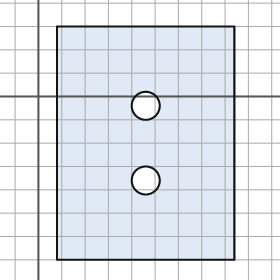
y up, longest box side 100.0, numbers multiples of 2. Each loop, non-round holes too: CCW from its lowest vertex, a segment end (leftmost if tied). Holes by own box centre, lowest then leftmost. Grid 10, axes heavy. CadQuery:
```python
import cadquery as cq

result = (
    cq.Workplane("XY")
    .moveTo(8.0, -70.0)
    .lineTo(84.0, -70.0)
    .lineTo(84.0, 30.0)
    .lineTo(8.0, 30.0)
    .close()
    .moveTo(46.0, -36.0)
    .circle(6.0)
    .moveTo(46.0, -4.0)
    .circle(6.0)
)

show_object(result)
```